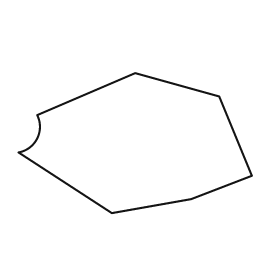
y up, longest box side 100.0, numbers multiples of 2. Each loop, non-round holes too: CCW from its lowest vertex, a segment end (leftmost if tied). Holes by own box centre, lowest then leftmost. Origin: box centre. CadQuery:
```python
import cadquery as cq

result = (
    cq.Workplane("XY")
    .moveTo(-10.0, -30.0)
    .lineTo(24.0, -24.0)
    .lineTo(50.0, -14.0)
    .lineTo(36.0, 20.0)
    .lineTo(0.0, 30.0)
    .lineTo(-42.0, 12.0)
    .threePointArc((-42.0, 2.0), (-50.0, -4.0))
    .close()
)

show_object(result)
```